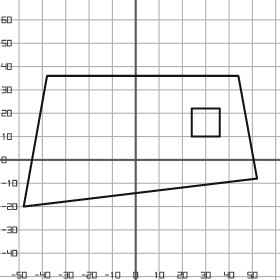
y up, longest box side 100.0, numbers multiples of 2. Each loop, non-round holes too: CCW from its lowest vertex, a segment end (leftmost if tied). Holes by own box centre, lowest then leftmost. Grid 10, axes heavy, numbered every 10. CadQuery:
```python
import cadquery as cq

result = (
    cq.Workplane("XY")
    .moveTo(-48.0, -20.0)
    .lineTo(52.0, -8.0)
    .lineTo(44.0, 36.0)
    .lineTo(-38.0, 36.0)
    .close()
    .moveTo(24.0, 10.0)
    .lineTo(36.0, 10.0)
    .lineTo(36.0, 22.0)
    .lineTo(24.0, 22.0)
    .close()
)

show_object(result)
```